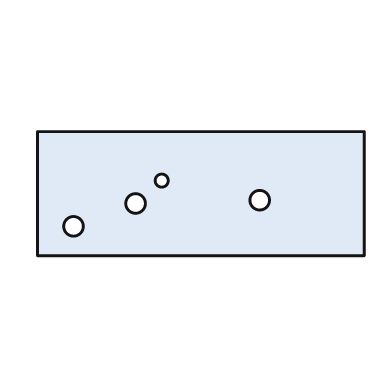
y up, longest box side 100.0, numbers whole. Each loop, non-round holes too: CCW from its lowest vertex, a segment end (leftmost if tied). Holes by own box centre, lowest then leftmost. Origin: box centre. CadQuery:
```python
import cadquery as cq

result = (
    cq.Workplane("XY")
    .moveTo(-50.0, -19.0)
    .lineTo(50.0, -19.0)
    .lineTo(50.0, 19.0)
    .lineTo(-50.0, 19.0)
    .close()
    .moveTo(-39.0, -10.0)
    .circle(3.0)
    .moveTo(-20.0, -3.0)
    .circle(3.0)
    .moveTo(18.0, -2.0)
    .circle(3.0)
    .moveTo(-12.0, 4.0)
    .circle(2.0)
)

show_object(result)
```